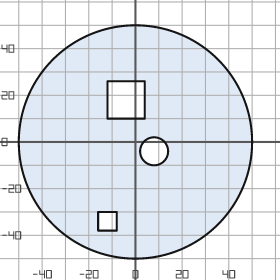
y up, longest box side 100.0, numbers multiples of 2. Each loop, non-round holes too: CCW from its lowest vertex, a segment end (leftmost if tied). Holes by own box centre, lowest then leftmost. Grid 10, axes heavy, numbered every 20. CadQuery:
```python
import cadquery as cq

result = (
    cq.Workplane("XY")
    .moveTo(0.0, 0.0)
    .circle(50.0)
    .moveTo(-16.0, -38.0)
    .lineTo(-8.0, -38.0)
    .lineTo(-8.0, -30.0)
    .lineTo(-16.0, -30.0)
    .close()
    .moveTo(8.0, -4.0)
    .circle(6.0)
    .moveTo(-12.0, 10.0)
    .lineTo(4.0, 10.0)
    .lineTo(4.0, 26.0)
    .lineTo(-12.0, 26.0)
    .close()
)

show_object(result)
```